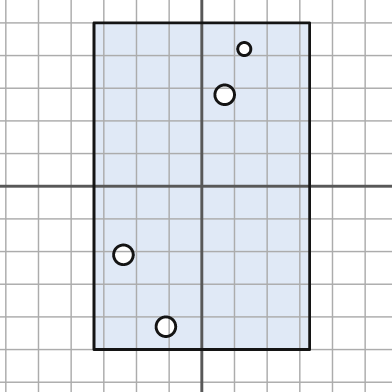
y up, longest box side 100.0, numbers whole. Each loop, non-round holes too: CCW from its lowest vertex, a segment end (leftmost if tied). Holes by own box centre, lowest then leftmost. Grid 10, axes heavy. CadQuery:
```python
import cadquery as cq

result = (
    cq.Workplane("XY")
    .moveTo(-33.0, -50.0)
    .lineTo(33.0, -50.0)
    .lineTo(33.0, 50.0)
    .lineTo(-33.0, 50.0)
    .close()
    .moveTo(-11.0, -43.0)
    .circle(3.0)
    .moveTo(-24.0, -21.0)
    .circle(3.0)
    .moveTo(7.0, 28.0)
    .circle(3.0)
    .moveTo(13.0, 42.0)
    .circle(2.0)
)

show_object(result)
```